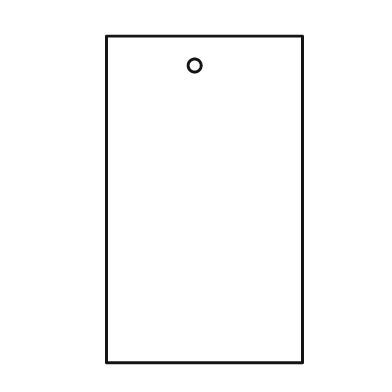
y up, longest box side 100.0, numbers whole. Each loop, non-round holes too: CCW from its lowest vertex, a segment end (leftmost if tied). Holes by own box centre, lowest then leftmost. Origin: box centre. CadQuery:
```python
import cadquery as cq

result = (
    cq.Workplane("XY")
    .moveTo(-30.0, -50.0)
    .lineTo(30.0, -50.0)
    .lineTo(30.0, 50.0)
    .lineTo(-30.0, 50.0)
    .close()
    .moveTo(-3.0, 41.0)
    .circle(2.0)
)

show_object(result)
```